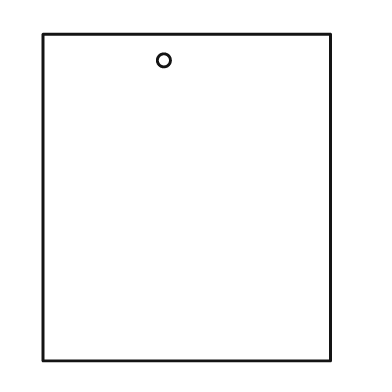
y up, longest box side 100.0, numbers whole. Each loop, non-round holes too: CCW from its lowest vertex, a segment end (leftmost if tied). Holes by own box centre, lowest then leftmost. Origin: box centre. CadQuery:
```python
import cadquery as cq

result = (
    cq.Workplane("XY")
    .moveTo(-44.0, -50.0)
    .lineTo(44.0, -50.0)
    .lineTo(44.0, 50.0)
    .lineTo(-44.0, 50.0)
    .close()
    .moveTo(-7.0, 42.0)
    .circle(2.0)
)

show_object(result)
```